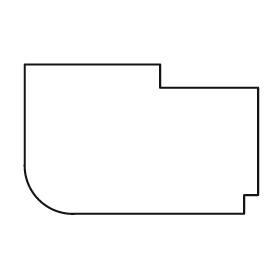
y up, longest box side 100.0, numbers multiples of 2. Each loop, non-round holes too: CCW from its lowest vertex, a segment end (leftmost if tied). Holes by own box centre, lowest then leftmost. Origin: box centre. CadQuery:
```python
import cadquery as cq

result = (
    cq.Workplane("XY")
    .moveTo(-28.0, -32.0)
    .lineTo(44.0, -32.0)
    .lineTo(44.0, -24.0)
    .lineTo(50.0, -24.0)
    .lineTo(50.0, 22.0)
    .lineTo(8.0, 22.0)
    .lineTo(8.0, 32.0)
    .lineTo(-50.0, 32.0)
    .lineTo(-50.0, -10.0)
    .threePointArc((-44.0, -26.0), (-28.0, -32.0))
    .close()
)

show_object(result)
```